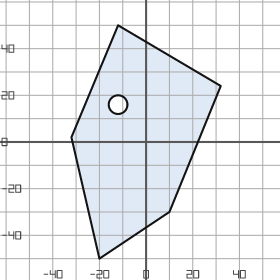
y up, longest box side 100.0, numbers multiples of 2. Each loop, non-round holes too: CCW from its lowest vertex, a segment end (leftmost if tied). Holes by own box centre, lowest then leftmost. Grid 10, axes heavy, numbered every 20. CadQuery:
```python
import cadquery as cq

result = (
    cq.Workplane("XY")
    .moveTo(-20.0, -50.0)
    .lineTo(10.0, -30.0)
    .lineTo(32.0, 24.0)
    .lineTo(-12.0, 50.0)
    .lineTo(-32.0, 2.0)
    .close()
    .moveTo(-12.0, 16.0)
    .circle(4.0)
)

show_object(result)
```